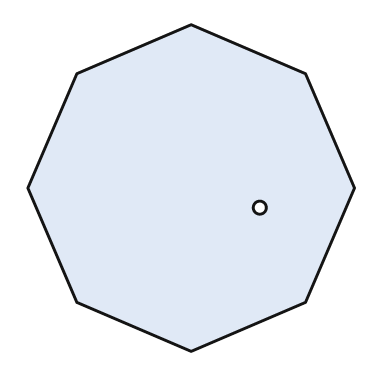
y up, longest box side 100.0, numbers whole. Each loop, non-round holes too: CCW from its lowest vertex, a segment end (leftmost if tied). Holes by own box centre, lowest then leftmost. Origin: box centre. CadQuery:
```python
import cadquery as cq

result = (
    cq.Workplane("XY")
    .moveTo(0.0, -50.0)
    .lineTo(35.0, -35.0)
    .lineTo(50.0, 0.0)
    .lineTo(35.0, 35.0)
    .lineTo(0.0, 50.0)
    .lineTo(-35.0, 35.0)
    .lineTo(-50.0, 0.0)
    .lineTo(-35.0, -35.0)
    .close()
    .moveTo(21.0, -6.0)
    .circle(2.0)
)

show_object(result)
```